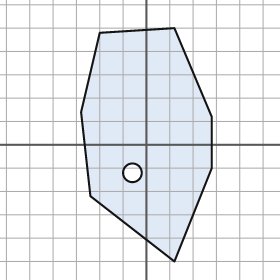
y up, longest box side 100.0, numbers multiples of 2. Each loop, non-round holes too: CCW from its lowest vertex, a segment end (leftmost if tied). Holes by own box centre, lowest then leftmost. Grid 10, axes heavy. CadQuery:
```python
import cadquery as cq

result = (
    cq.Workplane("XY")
    .moveTo(12.0, -50.0)
    .lineTo(28.0, -10.0)
    .lineTo(28.0, 12.0)
    .lineTo(12.0, 50.0)
    .lineTo(-20.0, 48.0)
    .lineTo(-28.0, 14.0)
    .lineTo(-24.0, -22.0)
    .close()
    .moveTo(-6.0, -12.0)
    .circle(4.0)
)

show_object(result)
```